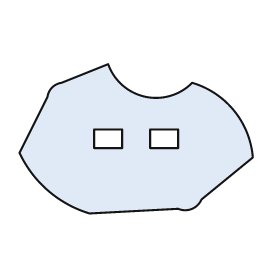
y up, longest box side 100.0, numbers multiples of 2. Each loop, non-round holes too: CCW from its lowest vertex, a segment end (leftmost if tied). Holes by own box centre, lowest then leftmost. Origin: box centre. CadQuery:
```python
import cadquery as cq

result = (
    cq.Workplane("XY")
    .moveTo(-20.0, -32.0)
    .lineTo(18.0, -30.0)
    .threePointArc((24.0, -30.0), (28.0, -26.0))
    .lineTo(50.0, -8.0)
    .threePointArc((42.0, 12.0), (24.0, 24.0))
    .threePointArc((4.0, 18.0), (-12.0, 32.0))
    .lineTo(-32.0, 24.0)
    .threePointArc((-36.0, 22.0), (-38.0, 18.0))
    .lineTo(-50.0, -6.0)
    .threePointArc((-38.0, -22.0), (-20.0, -32.0))
    .close()
    .moveTo(-18.0, -4.0)
    .lineTo(-6.0, -4.0)
    .lineTo(-6.0, 4.0)
    .lineTo(-18.0, 4.0)
    .close()
    .moveTo(6.0, -4.0)
    .lineTo(18.0, -4.0)
    .lineTo(18.0, 4.0)
    .lineTo(6.0, 4.0)
    .close()
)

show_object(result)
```